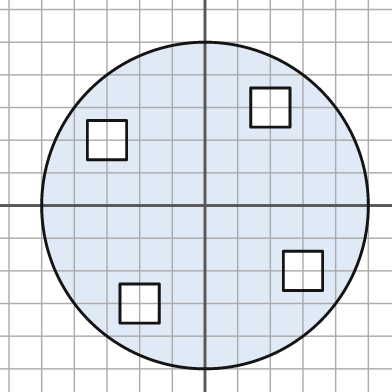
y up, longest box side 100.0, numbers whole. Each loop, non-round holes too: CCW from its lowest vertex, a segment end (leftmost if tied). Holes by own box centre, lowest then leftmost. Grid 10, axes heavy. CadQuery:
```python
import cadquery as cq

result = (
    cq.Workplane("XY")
    .moveTo(0.0, 0.0)
    .circle(50.0)
    .moveTo(-26.0, -36.0)
    .lineTo(-14.0, -36.0)
    .lineTo(-14.0, -24.0)
    .lineTo(-26.0, -24.0)
    .close()
    .moveTo(24.0, -26.0)
    .lineTo(36.0, -26.0)
    .lineTo(36.0, -14.0)
    .lineTo(24.0, -14.0)
    .close()
    .moveTo(-36.0, 14.0)
    .lineTo(-24.0, 14.0)
    .lineTo(-24.0, 26.0)
    .lineTo(-36.0, 26.0)
    .close()
    .moveTo(14.0, 24.0)
    .lineTo(26.0, 24.0)
    .lineTo(26.0, 36.0)
    .lineTo(14.0, 36.0)
    .close()
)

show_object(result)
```